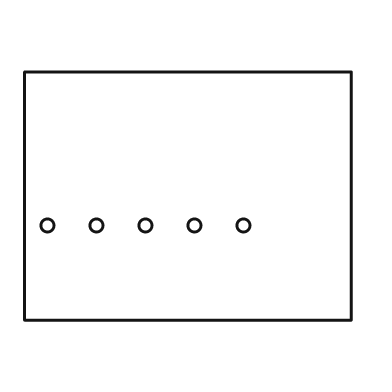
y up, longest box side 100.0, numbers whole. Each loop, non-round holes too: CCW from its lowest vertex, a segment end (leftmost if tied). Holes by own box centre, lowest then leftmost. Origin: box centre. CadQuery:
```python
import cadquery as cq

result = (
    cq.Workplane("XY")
    .moveTo(-50.0, -38.0)
    .lineTo(50.0, -38.0)
    .lineTo(50.0, 38.0)
    .lineTo(-50.0, 38.0)
    .close()
    .moveTo(-43.0, -9.0)
    .circle(2.0)
    .moveTo(-28.0, -9.0)
    .circle(2.0)
    .moveTo(-13.0, -9.0)
    .circle(2.0)
    .moveTo(2.0, -9.0)
    .circle(2.0)
    .moveTo(17.0, -9.0)
    .circle(2.0)
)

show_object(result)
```